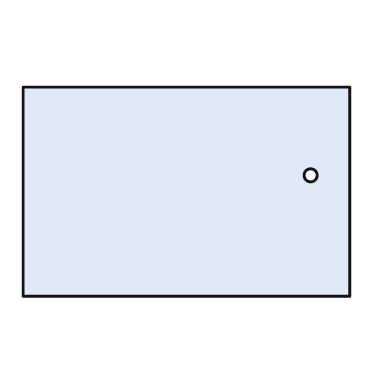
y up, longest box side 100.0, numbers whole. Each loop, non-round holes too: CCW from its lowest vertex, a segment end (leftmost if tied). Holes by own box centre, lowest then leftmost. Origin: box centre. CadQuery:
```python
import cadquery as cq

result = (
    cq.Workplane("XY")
    .moveTo(-50.0, -32.0)
    .lineTo(50.0, -32.0)
    .lineTo(50.0, 32.0)
    .lineTo(-50.0, 32.0)
    .close()
    .moveTo(38.0, 5.0)
    .circle(2.0)
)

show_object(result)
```